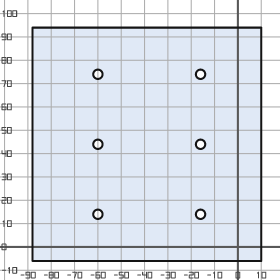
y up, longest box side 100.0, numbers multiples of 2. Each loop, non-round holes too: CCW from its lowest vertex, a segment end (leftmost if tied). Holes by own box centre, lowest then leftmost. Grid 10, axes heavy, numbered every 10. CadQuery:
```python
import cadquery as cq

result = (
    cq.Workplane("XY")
    .moveTo(-88.0, -6.0)
    .lineTo(10.0, -6.0)
    .lineTo(10.0, 94.0)
    .lineTo(-88.0, 94.0)
    .close()
    .moveTo(-60.0, 14.0)
    .circle(2.0)
    .moveTo(-16.0, 14.0)
    .circle(2.0)
    .moveTo(-60.0, 44.0)
    .circle(2.0)
    .moveTo(-16.0, 44.0)
    .circle(2.0)
    .moveTo(-60.0, 74.0)
    .circle(2.0)
    .moveTo(-16.0, 74.0)
    .circle(2.0)
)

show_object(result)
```